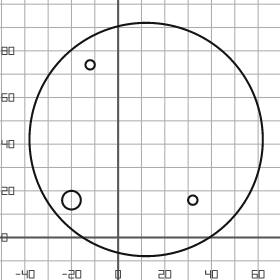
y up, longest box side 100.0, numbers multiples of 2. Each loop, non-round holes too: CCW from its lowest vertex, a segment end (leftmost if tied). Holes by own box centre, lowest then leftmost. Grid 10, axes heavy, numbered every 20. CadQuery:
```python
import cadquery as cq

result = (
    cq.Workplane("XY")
    .moveTo(12.0, 42.0)
    .circle(50.0)
    .moveTo(-20.0, 16.0)
    .circle(4.0)
    .moveTo(32.0, 16.0)
    .circle(2.0)
    .moveTo(-12.0, 74.0)
    .circle(2.0)
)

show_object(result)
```